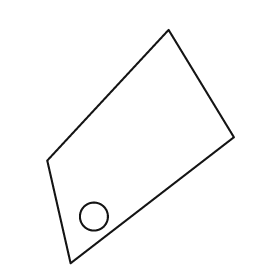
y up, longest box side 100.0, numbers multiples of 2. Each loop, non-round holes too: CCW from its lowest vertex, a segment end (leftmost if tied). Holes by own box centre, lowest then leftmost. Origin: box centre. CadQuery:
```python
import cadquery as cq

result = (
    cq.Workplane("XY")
    .moveTo(-30.0, -50.0)
    .lineTo(40.0, 4.0)
    .lineTo(12.0, 50.0)
    .lineTo(-40.0, -6.0)
    .close()
    .moveTo(-20.0, -30.0)
    .circle(6.0)
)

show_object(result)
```